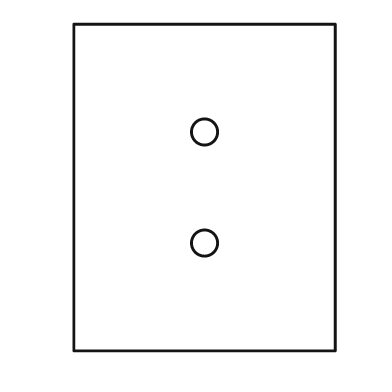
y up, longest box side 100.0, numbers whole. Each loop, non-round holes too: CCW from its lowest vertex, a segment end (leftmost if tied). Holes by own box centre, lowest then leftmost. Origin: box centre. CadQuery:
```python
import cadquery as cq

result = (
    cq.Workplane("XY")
    .moveTo(-40.0, -50.0)
    .lineTo(40.0, -50.0)
    .lineTo(40.0, 50.0)
    .lineTo(-40.0, 50.0)
    .close()
    .moveTo(0.0, -17.0)
    .circle(4.0)
    .moveTo(0.0, 17.0)
    .circle(4.0)
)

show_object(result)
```